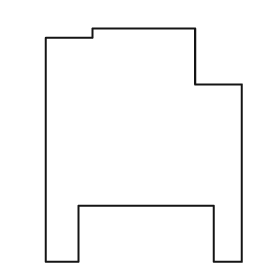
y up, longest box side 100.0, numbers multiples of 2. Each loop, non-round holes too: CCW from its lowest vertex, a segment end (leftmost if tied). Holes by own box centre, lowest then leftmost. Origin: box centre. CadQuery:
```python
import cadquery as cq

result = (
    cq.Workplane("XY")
    .moveTo(-42.0, -50.0)
    .lineTo(-28.0, -50.0)
    .lineTo(-28.0, -26.0)
    .lineTo(30.0, -26.0)
    .lineTo(30.0, -50.0)
    .lineTo(42.0, -50.0)
    .lineTo(42.0, 26.0)
    .lineTo(22.0, 26.0)
    .lineTo(22.0, 50.0)
    .lineTo(-22.0, 50.0)
    .lineTo(-22.0, 46.0)
    .lineTo(-42.0, 46.0)
    .close()
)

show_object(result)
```